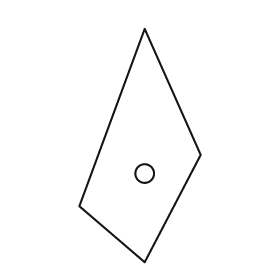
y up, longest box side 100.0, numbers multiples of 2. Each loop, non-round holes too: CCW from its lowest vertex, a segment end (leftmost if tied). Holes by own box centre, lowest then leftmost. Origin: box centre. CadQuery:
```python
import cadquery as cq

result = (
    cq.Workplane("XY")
    .moveTo(2.0, -50.0)
    .lineTo(26.0, -4.0)
    .lineTo(2.0, 50.0)
    .lineTo(-26.0, -26.0)
    .close()
    .moveTo(2.0, -12.0)
    .circle(4.0)
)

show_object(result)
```